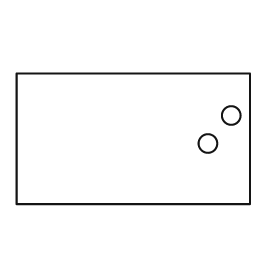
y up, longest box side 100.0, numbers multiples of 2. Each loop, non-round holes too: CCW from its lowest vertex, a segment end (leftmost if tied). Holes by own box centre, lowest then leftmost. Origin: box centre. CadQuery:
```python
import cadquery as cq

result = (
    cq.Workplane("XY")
    .moveTo(-50.0, -28.0)
    .lineTo(50.0, -28.0)
    .lineTo(50.0, 28.0)
    .lineTo(-50.0, 28.0)
    .close()
    .moveTo(32.0, -2.0)
    .circle(4.0)
    .moveTo(42.0, 10.0)
    .circle(4.0)
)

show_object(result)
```